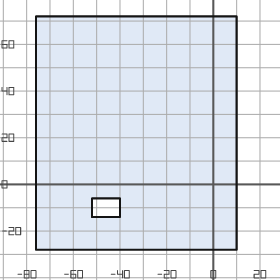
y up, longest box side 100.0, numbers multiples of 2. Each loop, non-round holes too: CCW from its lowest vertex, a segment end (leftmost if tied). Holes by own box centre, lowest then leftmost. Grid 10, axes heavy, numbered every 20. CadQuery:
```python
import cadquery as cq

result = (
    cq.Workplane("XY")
    .moveTo(-76.0, -28.0)
    .lineTo(10.0, -28.0)
    .lineTo(10.0, 72.0)
    .lineTo(-76.0, 72.0)
    .close()
    .moveTo(-52.0, -14.0)
    .lineTo(-40.0, -14.0)
    .lineTo(-40.0, -6.0)
    .lineTo(-52.0, -6.0)
    .close()
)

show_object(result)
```